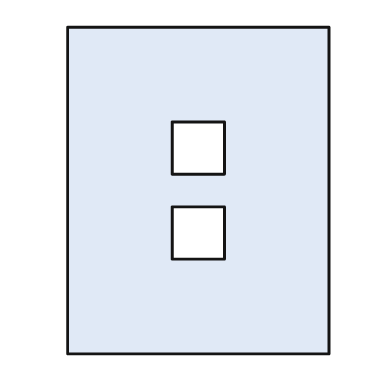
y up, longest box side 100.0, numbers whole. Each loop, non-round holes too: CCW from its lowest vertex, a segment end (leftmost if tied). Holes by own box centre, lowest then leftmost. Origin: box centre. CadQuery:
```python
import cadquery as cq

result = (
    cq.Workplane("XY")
    .moveTo(-40.0, -50.0)
    .lineTo(40.0, -50.0)
    .lineTo(40.0, 50.0)
    .lineTo(-40.0, 50.0)
    .close()
    .moveTo(-8.0, -21.0)
    .lineTo(8.0, -21.0)
    .lineTo(8.0, -5.0)
    .lineTo(-8.0, -5.0)
    .close()
    .moveTo(-8.0, 5.0)
    .lineTo(8.0, 5.0)
    .lineTo(8.0, 21.0)
    .lineTo(-8.0, 21.0)
    .close()
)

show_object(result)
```